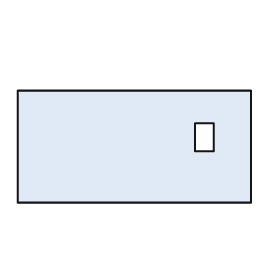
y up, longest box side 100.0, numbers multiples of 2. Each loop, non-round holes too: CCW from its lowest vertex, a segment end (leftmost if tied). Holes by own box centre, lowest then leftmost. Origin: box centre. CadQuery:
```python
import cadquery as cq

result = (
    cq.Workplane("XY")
    .moveTo(-50.0, -24.0)
    .lineTo(50.0, -24.0)
    .lineTo(50.0, 24.0)
    .lineTo(-50.0, 24.0)
    .close()
    .moveTo(26.0, -2.0)
    .lineTo(34.0, -2.0)
    .lineTo(34.0, 10.0)
    .lineTo(26.0, 10.0)
    .close()
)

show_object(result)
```